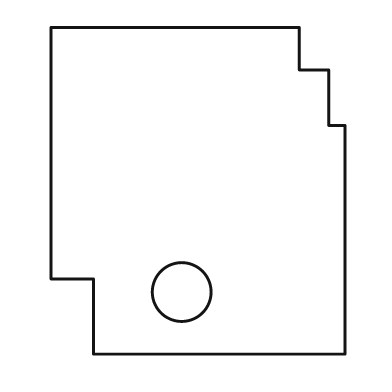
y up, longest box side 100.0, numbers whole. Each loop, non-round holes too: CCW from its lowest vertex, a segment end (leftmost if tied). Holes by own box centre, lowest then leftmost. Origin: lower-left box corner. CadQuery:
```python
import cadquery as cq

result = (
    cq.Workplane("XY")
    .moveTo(13.0, 0.0)
    .lineTo(90.0, 0.0)
    .lineTo(90.0, 70.0)
    .lineTo(85.0, 70.0)
    .lineTo(85.0, 87.0)
    .lineTo(76.0, 87.0)
    .lineTo(76.0, 100.0)
    .lineTo(0.0, 100.0)
    .lineTo(0.0, 23.0)
    .lineTo(13.0, 23.0)
    .close()
    .moveTo(40.0, 19.0)
    .circle(9.0)
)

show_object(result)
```